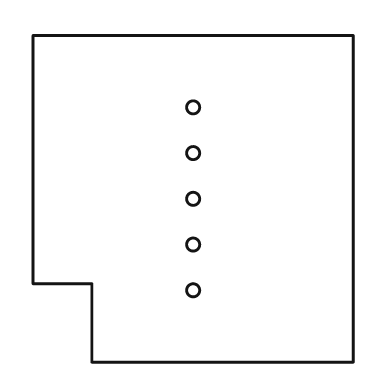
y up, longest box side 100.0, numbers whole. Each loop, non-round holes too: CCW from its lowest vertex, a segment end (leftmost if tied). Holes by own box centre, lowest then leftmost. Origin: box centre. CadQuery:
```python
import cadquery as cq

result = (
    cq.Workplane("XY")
    .moveTo(-31.0, -50.0)
    .lineTo(49.0, -50.0)
    .lineTo(49.0, 50.0)
    .lineTo(-49.0, 50.0)
    .lineTo(-49.0, -26.0)
    .lineTo(-31.0, -26.0)
    .close()
    .moveTo(0.0, -28.0)
    .circle(2.0)
    .moveTo(0.0, -14.0)
    .circle(2.0)
    .moveTo(0.0, 0.0)
    .circle(2.0)
    .moveTo(0.0, 14.0)
    .circle(2.0)
    .moveTo(0.0, 28.0)
    .circle(2.0)
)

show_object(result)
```